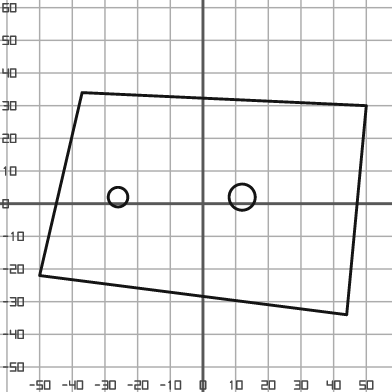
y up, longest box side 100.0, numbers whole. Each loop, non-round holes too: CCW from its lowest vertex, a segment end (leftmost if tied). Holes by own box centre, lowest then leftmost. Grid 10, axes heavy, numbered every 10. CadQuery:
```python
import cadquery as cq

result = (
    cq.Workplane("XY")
    .moveTo(44.0, -34.0)
    .lineTo(50.0, 30.0)
    .lineTo(-37.0, 34.0)
    .lineTo(-50.0, -22.0)
    .close()
    .moveTo(-26.0, 2.0)
    .circle(3.0)
    .moveTo(12.0, 2.0)
    .circle(4.0)
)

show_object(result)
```